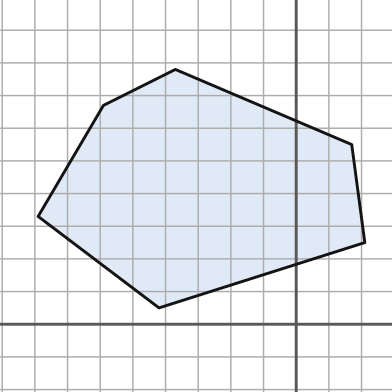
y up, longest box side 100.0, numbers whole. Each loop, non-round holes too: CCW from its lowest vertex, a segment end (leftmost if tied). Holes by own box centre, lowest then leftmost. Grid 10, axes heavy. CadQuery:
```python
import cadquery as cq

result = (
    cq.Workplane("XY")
    .moveTo(-42.0, 5.0)
    .lineTo(21.0, 25.0)
    .lineTo(17.0, 55.0)
    .lineTo(-37.0, 78.0)
    .lineTo(-59.0, 67.0)
    .lineTo(-79.0, 33.0)
    .close()
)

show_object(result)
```